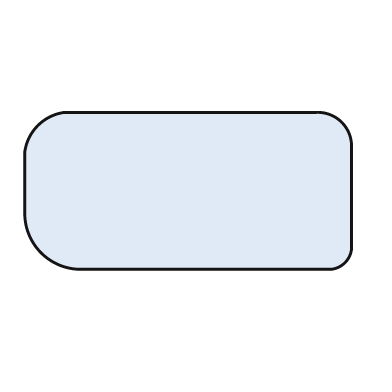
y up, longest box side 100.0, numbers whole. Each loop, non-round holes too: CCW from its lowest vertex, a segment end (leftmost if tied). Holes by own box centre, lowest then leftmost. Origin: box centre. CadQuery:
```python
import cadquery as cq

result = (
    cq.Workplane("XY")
    .moveTo(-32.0, -24.0)
    .lineTo(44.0, -24.0)
    .threePointArc((48.0, -22.0), (50.0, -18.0))
    .lineTo(50.0, 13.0)
    .threePointArc((47.0, 21.0), (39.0, 24.0))
    .lineTo(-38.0, 24.0)
    .threePointArc((-46.0, 20.0), (-50.0, 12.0))
    .lineTo(-50.0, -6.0)
    .threePointArc((-45.0, -19.0), (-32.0, -24.0))
    .close()
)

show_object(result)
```